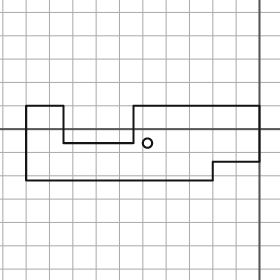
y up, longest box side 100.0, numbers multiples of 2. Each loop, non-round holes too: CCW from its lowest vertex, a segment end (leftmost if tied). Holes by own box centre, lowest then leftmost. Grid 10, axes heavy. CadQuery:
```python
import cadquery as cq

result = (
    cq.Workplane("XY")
    .moveTo(-100.0, -22.0)
    .lineTo(-20.0, -22.0)
    .lineTo(-20.0, -14.0)
    .lineTo(0.0, -14.0)
    .lineTo(0.0, 10.0)
    .lineTo(-54.0, 10.0)
    .lineTo(-54.0, -6.0)
    .lineTo(-84.0, -6.0)
    .lineTo(-84.0, 10.0)
    .lineTo(-100.0, 10.0)
    .close()
    .moveTo(-48.0, -6.0)
    .circle(2.0)
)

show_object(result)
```